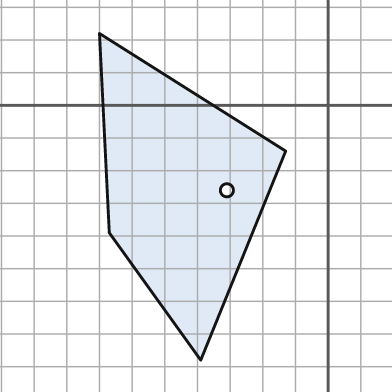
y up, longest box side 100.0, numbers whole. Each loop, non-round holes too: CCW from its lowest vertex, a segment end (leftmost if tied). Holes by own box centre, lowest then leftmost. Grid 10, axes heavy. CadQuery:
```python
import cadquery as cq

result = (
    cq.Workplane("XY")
    .moveTo(-39.0, -78.0)
    .lineTo(-13.0, -14.0)
    .lineTo(-70.0, 22.0)
    .lineTo(-67.0, -39.0)
    .close()
    .moveTo(-31.0, -26.0)
    .circle(2.0)
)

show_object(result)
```